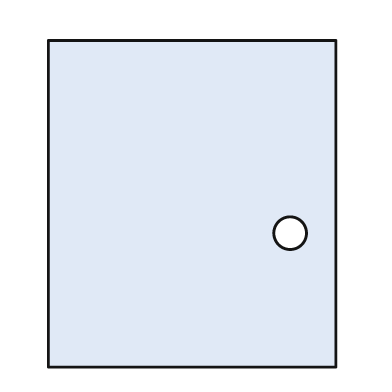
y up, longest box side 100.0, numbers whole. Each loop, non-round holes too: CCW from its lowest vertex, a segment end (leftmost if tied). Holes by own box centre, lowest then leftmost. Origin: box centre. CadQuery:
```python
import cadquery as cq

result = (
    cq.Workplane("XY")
    .moveTo(-44.0, -50.0)
    .lineTo(44.0, -50.0)
    .lineTo(44.0, 50.0)
    .lineTo(-44.0, 50.0)
    .close()
    .moveTo(30.0, -9.0)
    .circle(5.0)
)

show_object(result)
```